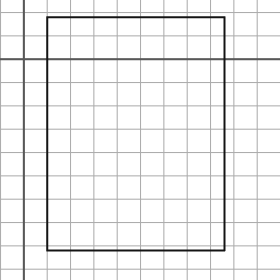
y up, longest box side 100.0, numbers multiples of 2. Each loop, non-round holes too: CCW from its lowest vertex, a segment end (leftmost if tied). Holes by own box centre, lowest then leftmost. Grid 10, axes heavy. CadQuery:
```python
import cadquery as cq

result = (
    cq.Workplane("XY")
    .moveTo(10.0, -82.0)
    .lineTo(86.0, -82.0)
    .lineTo(86.0, 18.0)
    .lineTo(10.0, 18.0)
    .close()
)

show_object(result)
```